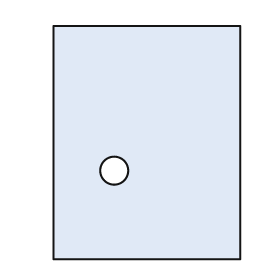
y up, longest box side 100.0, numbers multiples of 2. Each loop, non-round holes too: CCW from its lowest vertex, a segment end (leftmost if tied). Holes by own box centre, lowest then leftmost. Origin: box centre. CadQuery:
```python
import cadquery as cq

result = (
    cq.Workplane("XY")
    .moveTo(-40.0, -50.0)
    .lineTo(40.0, -50.0)
    .lineTo(40.0, 50.0)
    .lineTo(-40.0, 50.0)
    .close()
    .moveTo(-14.0, -12.0)
    .circle(6.0)
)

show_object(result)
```